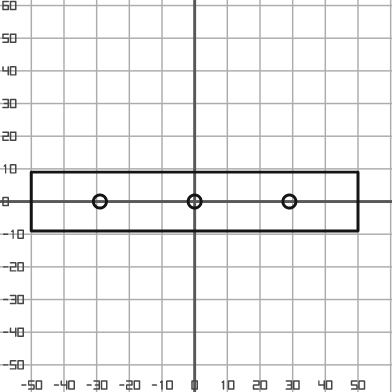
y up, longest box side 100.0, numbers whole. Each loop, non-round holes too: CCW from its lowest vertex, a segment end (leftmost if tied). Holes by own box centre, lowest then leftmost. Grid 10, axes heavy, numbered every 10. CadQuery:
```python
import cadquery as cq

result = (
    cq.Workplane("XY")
    .moveTo(-50.0, -9.0)
    .lineTo(50.0, -9.0)
    .lineTo(50.0, 9.0)
    .lineTo(-50.0, 9.0)
    .close()
    .moveTo(-29.0, 0.0)
    .circle(2.0)
    .moveTo(0.0, 0.0)
    .circle(2.0)
    .moveTo(29.0, 0.0)
    .circle(2.0)
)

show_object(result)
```